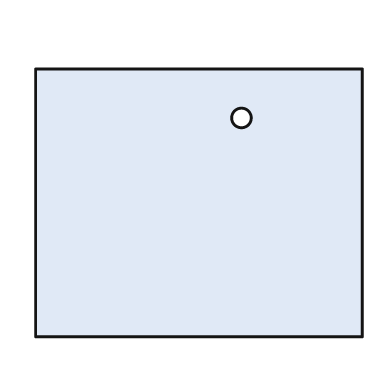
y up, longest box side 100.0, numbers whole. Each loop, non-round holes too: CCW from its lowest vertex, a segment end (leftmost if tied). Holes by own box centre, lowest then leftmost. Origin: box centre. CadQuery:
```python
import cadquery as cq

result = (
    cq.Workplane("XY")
    .moveTo(-50.0, -41.0)
    .lineTo(50.0, -41.0)
    .lineTo(50.0, 41.0)
    .lineTo(-50.0, 41.0)
    .close()
    .moveTo(13.0, 26.0)
    .circle(3.0)
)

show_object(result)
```